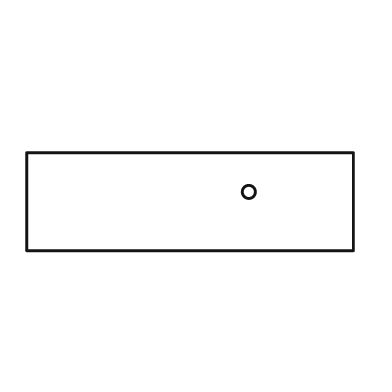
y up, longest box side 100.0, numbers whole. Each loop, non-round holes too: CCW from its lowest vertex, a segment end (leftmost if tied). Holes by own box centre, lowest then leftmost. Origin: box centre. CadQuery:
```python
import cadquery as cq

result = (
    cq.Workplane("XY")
    .moveTo(-50.0, -15.0)
    .lineTo(50.0, -15.0)
    .lineTo(50.0, 15.0)
    .lineTo(-50.0, 15.0)
    .close()
    .moveTo(18.0, 3.0)
    .circle(2.0)
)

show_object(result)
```